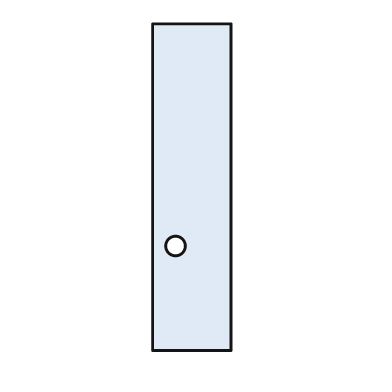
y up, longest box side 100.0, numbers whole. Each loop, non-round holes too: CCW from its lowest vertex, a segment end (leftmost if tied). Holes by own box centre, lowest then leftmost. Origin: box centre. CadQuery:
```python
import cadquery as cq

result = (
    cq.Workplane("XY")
    .moveTo(-12.0, -50.0)
    .lineTo(12.0, -50.0)
    .lineTo(12.0, 50.0)
    .lineTo(-12.0, 50.0)
    .close()
    .moveTo(-5.0, -18.0)
    .circle(3.0)
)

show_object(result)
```